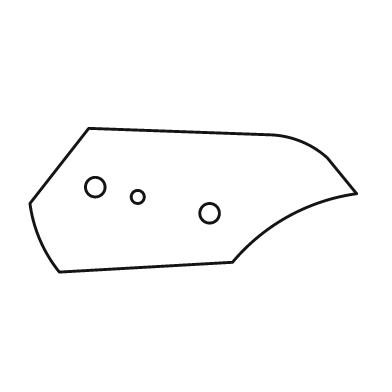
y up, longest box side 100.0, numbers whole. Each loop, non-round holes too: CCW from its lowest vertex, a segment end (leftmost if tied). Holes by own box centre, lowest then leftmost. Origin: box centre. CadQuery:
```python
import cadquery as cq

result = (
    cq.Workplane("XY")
    .moveTo(-41.0, -22.0)
    .lineTo(12.0, -19.0)
    .threePointArc((29.0, -5.0), (50.0, 2.0))
    .lineTo(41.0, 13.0)
    .threePointArc((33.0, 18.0), (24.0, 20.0))
    .lineTo(-32.0, 22.0)
    .lineTo(-50.0, -1.0)
    .threePointArc((-47.0, -12.0), (-41.0, -22.0))
    .close()
    .moveTo(5.0, -4.0)
    .circle(3.0)
    .moveTo(-17.0, 1.0)
    .circle(2.0)
    .moveTo(-30.0, 4.0)
    .circle(3.0)
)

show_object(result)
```